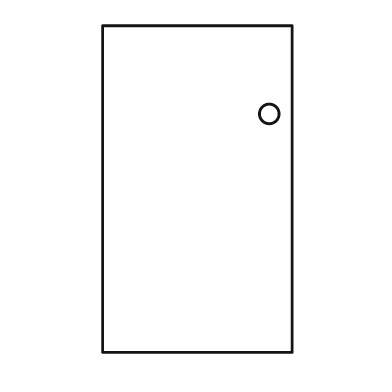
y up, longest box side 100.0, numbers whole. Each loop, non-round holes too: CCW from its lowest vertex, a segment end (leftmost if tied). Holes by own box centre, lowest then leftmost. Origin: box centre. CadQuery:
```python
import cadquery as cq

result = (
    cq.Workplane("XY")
    .moveTo(-29.0, -50.0)
    .lineTo(29.0, -50.0)
    .lineTo(29.0, 50.0)
    .lineTo(-29.0, 50.0)
    .close()
    .moveTo(22.0, 23.0)
    .circle(3.0)
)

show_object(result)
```